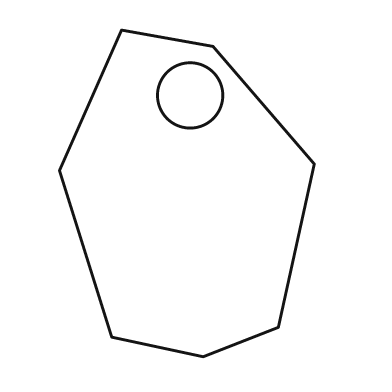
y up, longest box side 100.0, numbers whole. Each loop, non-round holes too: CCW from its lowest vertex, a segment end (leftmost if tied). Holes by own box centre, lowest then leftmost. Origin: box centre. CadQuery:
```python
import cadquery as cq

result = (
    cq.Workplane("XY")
    .moveTo(5.0, -50.0)
    .lineTo(28.0, -41.0)
    .lineTo(39.0, 9.0)
    .lineTo(8.0, 45.0)
    .lineTo(-20.0, 50.0)
    .lineTo(-39.0, 7.0)
    .lineTo(-23.0, -44.0)
    .close()
    .moveTo(1.0, 30.0)
    .circle(10.0)
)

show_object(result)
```